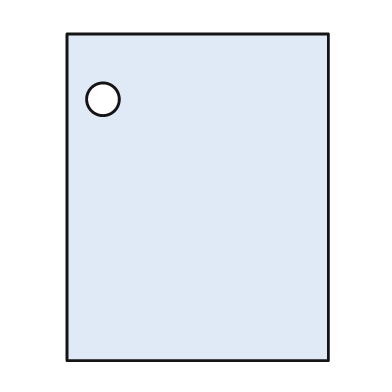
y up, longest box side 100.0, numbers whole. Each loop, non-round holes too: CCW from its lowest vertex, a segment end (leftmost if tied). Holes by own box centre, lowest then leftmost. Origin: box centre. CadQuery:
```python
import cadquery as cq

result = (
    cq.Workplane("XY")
    .moveTo(-40.0, -50.0)
    .lineTo(40.0, -50.0)
    .lineTo(40.0, 50.0)
    .lineTo(-40.0, 50.0)
    .close()
    .moveTo(-29.0, 30.0)
    .circle(5.0)
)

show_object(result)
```